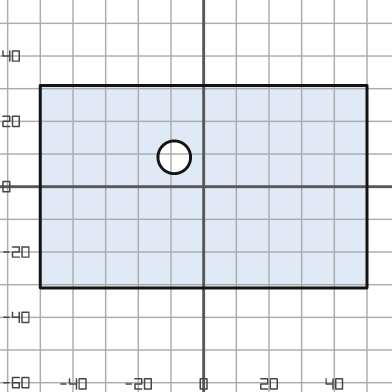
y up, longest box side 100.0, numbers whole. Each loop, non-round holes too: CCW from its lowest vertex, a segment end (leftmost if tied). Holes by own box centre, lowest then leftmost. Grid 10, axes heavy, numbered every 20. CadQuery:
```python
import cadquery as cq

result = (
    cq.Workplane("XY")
    .moveTo(-50.0, -31.0)
    .lineTo(50.0, -31.0)
    .lineTo(50.0, 31.0)
    .lineTo(-50.0, 31.0)
    .close()
    .moveTo(-9.0, 9.0)
    .circle(5.0)
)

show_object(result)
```